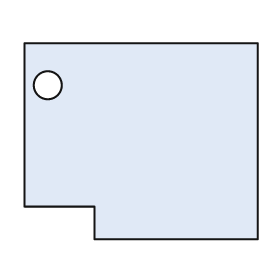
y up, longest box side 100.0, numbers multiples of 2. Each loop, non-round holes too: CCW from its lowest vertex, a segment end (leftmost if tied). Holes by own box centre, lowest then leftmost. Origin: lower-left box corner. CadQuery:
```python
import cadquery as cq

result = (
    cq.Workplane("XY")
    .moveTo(30.0, 0.0)
    .lineTo(100.0, 0.0)
    .lineTo(100.0, 84.0)
    .lineTo(0.0, 84.0)
    .lineTo(0.0, 14.0)
    .lineTo(30.0, 14.0)
    .close()
    .moveTo(10.0, 66.0)
    .circle(6.0)
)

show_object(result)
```